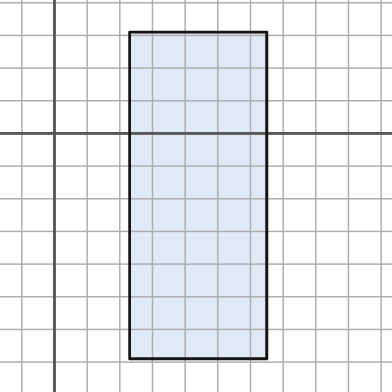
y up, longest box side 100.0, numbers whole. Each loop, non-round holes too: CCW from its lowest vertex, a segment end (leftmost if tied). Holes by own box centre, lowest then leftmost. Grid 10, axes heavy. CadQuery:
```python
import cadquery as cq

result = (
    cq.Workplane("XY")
    .moveTo(23.0, -69.0)
    .lineTo(65.0, -69.0)
    .lineTo(65.0, 31.0)
    .lineTo(23.0, 31.0)
    .close()
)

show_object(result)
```